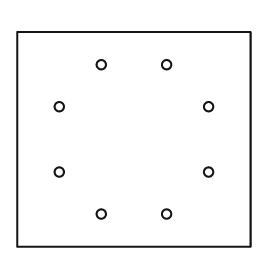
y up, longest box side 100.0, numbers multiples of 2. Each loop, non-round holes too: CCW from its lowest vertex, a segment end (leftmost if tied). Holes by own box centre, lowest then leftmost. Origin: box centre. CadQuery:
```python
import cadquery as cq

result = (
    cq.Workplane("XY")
    .moveTo(-50.0, -46.0)
    .lineTo(50.0, -46.0)
    .lineTo(50.0, 46.0)
    .lineTo(-50.0, 46.0)
    .close()
    .moveTo(-14.0, -32.0)
    .circle(2.0)
    .moveTo(14.0, -32.0)
    .circle(2.0)
    .moveTo(-32.0, -14.0)
    .circle(2.0)
    .moveTo(32.0, -14.0)
    .circle(2.0)
    .moveTo(-32.0, 14.0)
    .circle(2.0)
    .moveTo(32.0, 14.0)
    .circle(2.0)
    .moveTo(-14.0, 32.0)
    .circle(2.0)
    .moveTo(14.0, 32.0)
    .circle(2.0)
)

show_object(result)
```